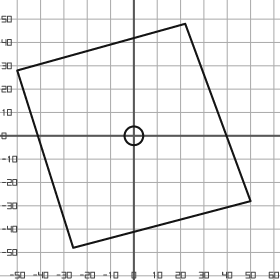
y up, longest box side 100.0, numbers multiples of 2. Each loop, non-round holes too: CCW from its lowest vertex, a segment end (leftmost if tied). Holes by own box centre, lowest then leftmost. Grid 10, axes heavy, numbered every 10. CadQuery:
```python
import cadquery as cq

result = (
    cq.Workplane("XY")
    .moveTo(-26.0, -48.0)
    .lineTo(50.0, -28.0)
    .lineTo(22.0, 48.0)
    .lineTo(-50.0, 28.0)
    .close()
    .moveTo(0.0, 0.0)
    .circle(4.0)
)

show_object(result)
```